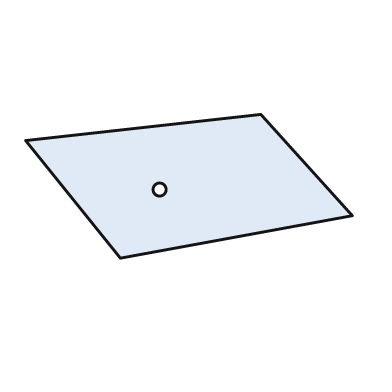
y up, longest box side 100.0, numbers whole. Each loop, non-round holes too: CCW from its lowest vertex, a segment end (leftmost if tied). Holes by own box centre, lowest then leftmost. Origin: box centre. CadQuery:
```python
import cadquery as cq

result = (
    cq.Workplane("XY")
    .moveTo(-21.0, -22.0)
    .lineTo(50.0, -9.0)
    .lineTo(22.0, 22.0)
    .lineTo(-50.0, 14.0)
    .close()
    .moveTo(-9.0, -1.0)
    .circle(2.0)
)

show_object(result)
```